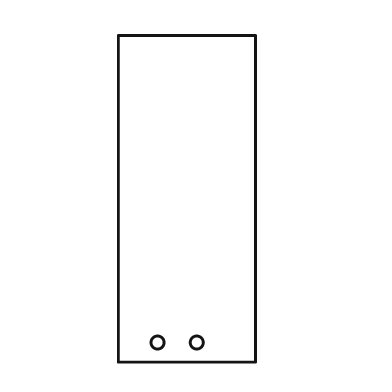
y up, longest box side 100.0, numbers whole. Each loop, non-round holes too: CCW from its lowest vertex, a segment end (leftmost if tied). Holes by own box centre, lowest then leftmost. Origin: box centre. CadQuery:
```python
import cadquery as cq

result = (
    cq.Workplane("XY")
    .moveTo(-21.0, -50.0)
    .lineTo(21.0, -50.0)
    .lineTo(21.0, 50.0)
    .lineTo(-21.0, 50.0)
    .close()
    .moveTo(-9.0, -44.0)
    .circle(2.0)
    .moveTo(3.0, -44.0)
    .circle(2.0)
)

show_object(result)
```